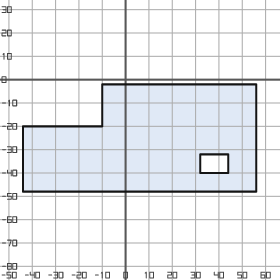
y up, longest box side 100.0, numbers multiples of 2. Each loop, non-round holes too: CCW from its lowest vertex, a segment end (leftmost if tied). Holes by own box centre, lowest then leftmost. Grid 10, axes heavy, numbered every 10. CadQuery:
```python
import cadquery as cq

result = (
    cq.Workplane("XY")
    .moveTo(-44.0, -48.0)
    .lineTo(56.0, -48.0)
    .lineTo(56.0, -2.0)
    .lineTo(-10.0, -2.0)
    .lineTo(-10.0, -20.0)
    .lineTo(-44.0, -20.0)
    .close()
    .moveTo(32.0, -40.0)
    .lineTo(44.0, -40.0)
    .lineTo(44.0, -32.0)
    .lineTo(32.0, -32.0)
    .close()
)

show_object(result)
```